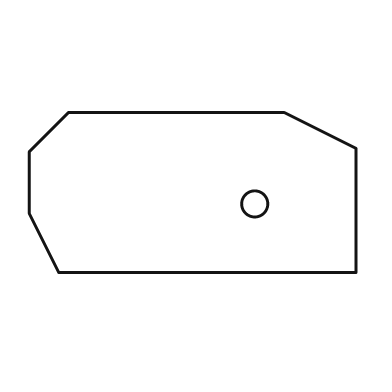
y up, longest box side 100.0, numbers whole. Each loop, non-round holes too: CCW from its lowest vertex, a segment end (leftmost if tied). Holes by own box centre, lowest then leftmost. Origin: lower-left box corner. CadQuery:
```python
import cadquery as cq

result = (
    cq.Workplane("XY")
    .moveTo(9.0, 0.0)
    .lineTo(100.0, 0.0)
    .lineTo(100.0, 38.0)
    .lineTo(78.0, 49.0)
    .lineTo(12.0, 49.0)
    .lineTo(0.0, 37.0)
    .lineTo(0.0, 18.0)
    .close()
    .moveTo(69.0, 21.0)
    .circle(4.0)
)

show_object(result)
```